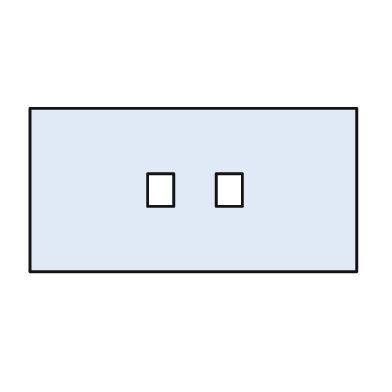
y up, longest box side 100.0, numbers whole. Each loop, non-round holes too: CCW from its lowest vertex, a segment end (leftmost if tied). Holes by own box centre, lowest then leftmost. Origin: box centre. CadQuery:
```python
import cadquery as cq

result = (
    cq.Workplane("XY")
    .moveTo(-50.0, -25.0)
    .lineTo(50.0, -25.0)
    .lineTo(50.0, 25.0)
    .lineTo(-50.0, 25.0)
    .close()
    .moveTo(-14.0, -5.0)
    .lineTo(-6.0, -5.0)
    .lineTo(-6.0, 5.0)
    .lineTo(-14.0, 5.0)
    .close()
    .moveTo(7.0, -5.0)
    .lineTo(15.0, -5.0)
    .lineTo(15.0, 5.0)
    .lineTo(7.0, 5.0)
    .close()
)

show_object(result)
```